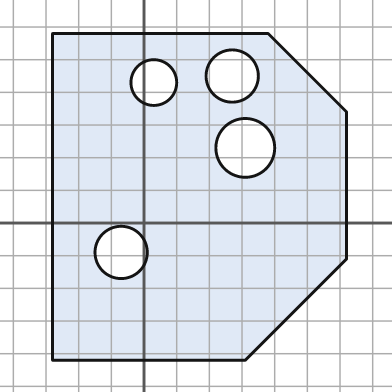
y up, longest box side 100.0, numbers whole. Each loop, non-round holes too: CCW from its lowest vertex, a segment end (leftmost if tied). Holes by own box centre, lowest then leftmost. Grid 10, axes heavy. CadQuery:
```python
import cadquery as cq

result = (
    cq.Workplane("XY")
    .moveTo(-28.0, -42.0)
    .lineTo(31.0, -42.0)
    .lineTo(62.0, -11.0)
    .lineTo(62.0, 34.0)
    .lineTo(38.0, 58.0)
    .lineTo(-28.0, 58.0)
    .close()
    .moveTo(-7.0, -9.0)
    .circle(8.0)
    .moveTo(31.0, 23.0)
    .circle(9.0)
    .moveTo(3.0, 43.0)
    .circle(7.0)
    .moveTo(27.0, 45.0)
    .circle(8.0)
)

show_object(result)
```